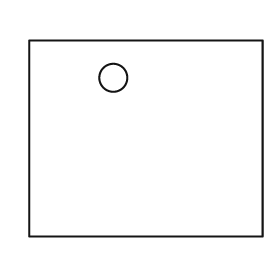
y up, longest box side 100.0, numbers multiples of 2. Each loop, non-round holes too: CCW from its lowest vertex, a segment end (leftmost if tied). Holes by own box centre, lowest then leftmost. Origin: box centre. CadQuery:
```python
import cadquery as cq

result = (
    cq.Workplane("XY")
    .moveTo(-50.0, -42.0)
    .lineTo(50.0, -42.0)
    .lineTo(50.0, 42.0)
    .lineTo(-50.0, 42.0)
    .close()
    .moveTo(-14.0, 26.0)
    .circle(6.0)
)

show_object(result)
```